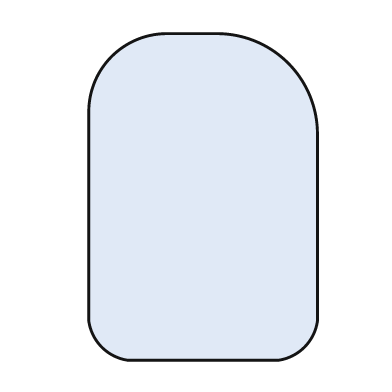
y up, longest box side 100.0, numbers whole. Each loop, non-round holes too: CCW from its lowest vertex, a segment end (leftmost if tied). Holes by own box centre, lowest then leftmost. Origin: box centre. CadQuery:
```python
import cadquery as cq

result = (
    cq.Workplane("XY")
    .moveTo(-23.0, -50.0)
    .lineTo(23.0, -50.0)
    .threePointArc((31.0, -46.0), (35.0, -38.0))
    .lineTo(35.0, 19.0)
    .threePointArc((26.0, 41.0), (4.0, 50.0))
    .lineTo(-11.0, 50.0)
    .threePointArc((-28.0, 43.0), (-35.0, 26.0))
    .lineTo(-35.0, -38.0)
    .threePointArc((-31.0, -46.0), (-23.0, -50.0))
    .close()
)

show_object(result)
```